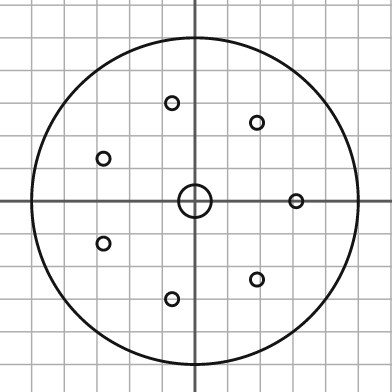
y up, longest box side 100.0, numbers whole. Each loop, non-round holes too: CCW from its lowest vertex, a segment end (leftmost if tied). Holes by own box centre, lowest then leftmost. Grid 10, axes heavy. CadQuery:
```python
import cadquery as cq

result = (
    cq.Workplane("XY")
    .moveTo(0.0, 0.0)
    .circle(50.0)
    .moveTo(-7.0, -30.0)
    .circle(2.0)
    .moveTo(19.0, -24.0)
    .circle(2.0)
    .moveTo(-28.0, -13.0)
    .circle(2.0)
    .moveTo(0.0, 0.0)
    .circle(5.0)
    .moveTo(31.0, 0.0)
    .circle(2.0)
    .moveTo(-28.0, 13.0)
    .circle(2.0)
    .moveTo(19.0, 24.0)
    .circle(2.0)
    .moveTo(-7.0, 30.0)
    .circle(2.0)
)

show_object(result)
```